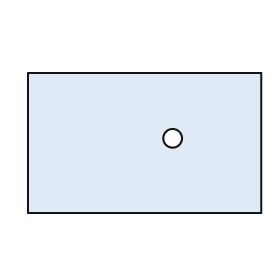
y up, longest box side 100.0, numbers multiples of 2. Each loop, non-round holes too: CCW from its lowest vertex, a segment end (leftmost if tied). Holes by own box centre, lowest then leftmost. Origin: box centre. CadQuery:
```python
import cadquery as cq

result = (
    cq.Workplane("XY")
    .moveTo(-50.0, -30.0)
    .lineTo(50.0, -30.0)
    .lineTo(50.0, 30.0)
    .lineTo(-50.0, 30.0)
    .close()
    .moveTo(12.0, 2.0)
    .circle(4.0)
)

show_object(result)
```